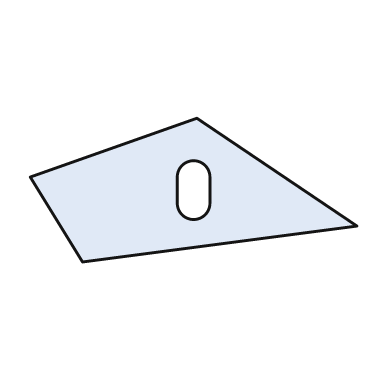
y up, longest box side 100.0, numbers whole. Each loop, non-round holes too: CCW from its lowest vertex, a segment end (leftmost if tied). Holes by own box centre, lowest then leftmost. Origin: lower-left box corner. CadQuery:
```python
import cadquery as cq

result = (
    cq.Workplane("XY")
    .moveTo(16.0, 0.0)
    .lineTo(100.0, 11.0)
    .lineTo(51.0, 44.0)
    .lineTo(0.0, 26.0)
    .close()
    .moveTo(45.0, 18.0)
    .threePointArc((50.0, 13.0), (55.0, 18.0))
    .lineTo(55.0, 26.0)
    .threePointArc((50.0, 31.0), (45.0, 26.0))
    .close()
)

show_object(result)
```